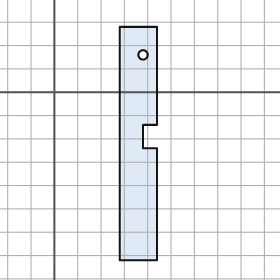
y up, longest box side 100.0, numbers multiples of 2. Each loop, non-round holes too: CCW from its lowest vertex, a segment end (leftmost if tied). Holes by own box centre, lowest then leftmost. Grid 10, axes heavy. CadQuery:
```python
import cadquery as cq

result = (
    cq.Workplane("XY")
    .moveTo(28.0, -72.0)
    .lineTo(44.0, -72.0)
    .lineTo(44.0, -24.0)
    .lineTo(38.0, -24.0)
    .lineTo(38.0, -14.0)
    .lineTo(44.0, -14.0)
    .lineTo(44.0, 28.0)
    .lineTo(28.0, 28.0)
    .close()
    .moveTo(38.0, 16.0)
    .circle(2.0)
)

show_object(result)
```